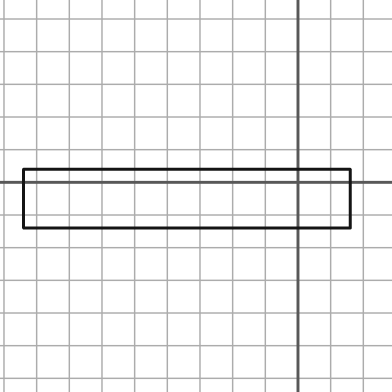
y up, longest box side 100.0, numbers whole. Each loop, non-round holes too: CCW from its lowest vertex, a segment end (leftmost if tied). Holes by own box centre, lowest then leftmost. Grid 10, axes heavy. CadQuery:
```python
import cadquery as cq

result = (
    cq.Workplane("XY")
    .moveTo(-84.0, -14.0)
    .lineTo(16.0, -14.0)
    .lineTo(16.0, 4.0)
    .lineTo(-84.0, 4.0)
    .close()
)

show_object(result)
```